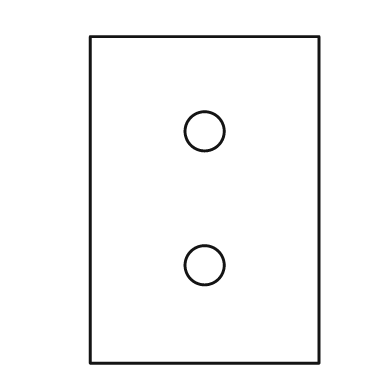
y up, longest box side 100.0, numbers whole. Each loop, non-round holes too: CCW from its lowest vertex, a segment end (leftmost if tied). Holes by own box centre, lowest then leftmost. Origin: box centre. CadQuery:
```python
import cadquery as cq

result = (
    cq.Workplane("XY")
    .moveTo(-35.0, -50.0)
    .lineTo(35.0, -50.0)
    .lineTo(35.0, 50.0)
    .lineTo(-35.0, 50.0)
    .close()
    .moveTo(0.0, -20.0)
    .circle(6.0)
    .moveTo(0.0, 21.0)
    .circle(6.0)
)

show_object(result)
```